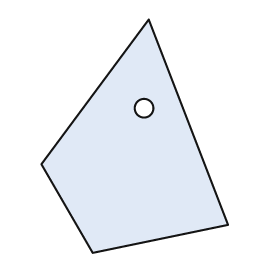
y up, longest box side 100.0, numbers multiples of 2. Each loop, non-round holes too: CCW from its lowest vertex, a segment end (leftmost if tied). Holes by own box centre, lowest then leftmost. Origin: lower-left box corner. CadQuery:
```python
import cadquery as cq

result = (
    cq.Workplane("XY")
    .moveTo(22.0, 0.0)
    .lineTo(80.0, 12.0)
    .lineTo(46.0, 100.0)
    .lineTo(0.0, 38.0)
    .close()
    .moveTo(44.0, 62.0)
    .circle(4.0)
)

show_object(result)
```